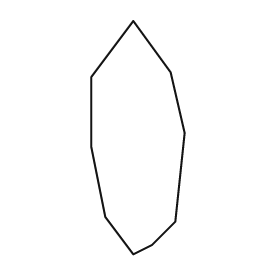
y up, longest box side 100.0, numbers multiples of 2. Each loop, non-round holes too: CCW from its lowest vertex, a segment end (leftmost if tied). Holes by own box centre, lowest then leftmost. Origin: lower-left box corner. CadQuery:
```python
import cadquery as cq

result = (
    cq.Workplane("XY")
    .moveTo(18.0, 0.0)
    .lineTo(26.0, 4.0)
    .lineTo(36.0, 14.0)
    .lineTo(40.0, 52.0)
    .lineTo(34.0, 78.0)
    .lineTo(18.0, 100.0)
    .lineTo(0.0, 76.0)
    .lineTo(0.0, 46.0)
    .lineTo(6.0, 16.0)
    .close()
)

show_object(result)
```